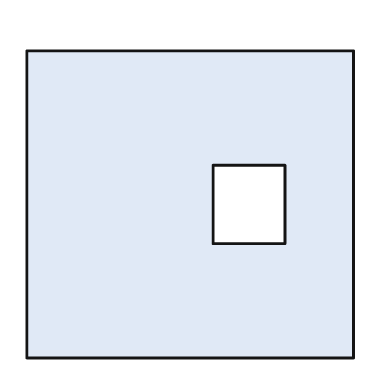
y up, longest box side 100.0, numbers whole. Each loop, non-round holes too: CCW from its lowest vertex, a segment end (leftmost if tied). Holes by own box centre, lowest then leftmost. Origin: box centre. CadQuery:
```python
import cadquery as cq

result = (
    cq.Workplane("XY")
    .moveTo(-50.0, -47.0)
    .lineTo(50.0, -47.0)
    .lineTo(50.0, 47.0)
    .lineTo(-50.0, 47.0)
    .close()
    .moveTo(7.0, -12.0)
    .lineTo(29.0, -12.0)
    .lineTo(29.0, 12.0)
    .lineTo(7.0, 12.0)
    .close()
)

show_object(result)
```